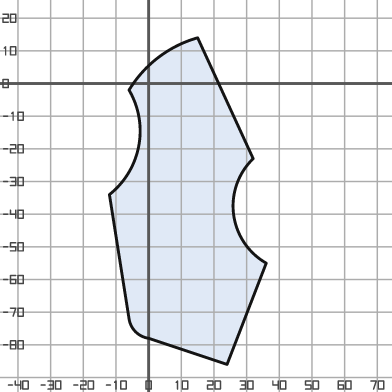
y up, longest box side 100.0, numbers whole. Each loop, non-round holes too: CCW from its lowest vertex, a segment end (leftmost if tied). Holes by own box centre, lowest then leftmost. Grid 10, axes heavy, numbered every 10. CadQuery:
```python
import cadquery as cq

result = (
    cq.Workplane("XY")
    .moveTo(24.0, -86.0)
    .lineTo(36.0, -55.0)
    .threePointArc((26.0, -40.0), (32.0, -23.0))
    .lineTo(15.0, 14.0)
    .threePointArc((3.0, 8.0), (-6.0, -2.0))
    .threePointArc((-3.0, -19.0), (-12.0, -34.0))
    .lineTo(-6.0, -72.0)
    .threePointArc((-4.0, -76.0), (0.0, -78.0))
    .close()
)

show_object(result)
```